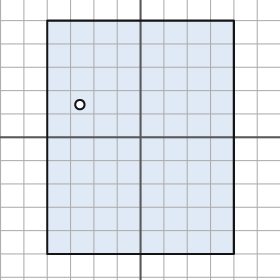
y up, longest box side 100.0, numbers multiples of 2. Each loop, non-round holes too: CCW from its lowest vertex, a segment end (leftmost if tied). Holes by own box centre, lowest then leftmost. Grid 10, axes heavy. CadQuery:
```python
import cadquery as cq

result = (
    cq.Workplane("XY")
    .moveTo(-40.0, -50.0)
    .lineTo(40.0, -50.0)
    .lineTo(40.0, 50.0)
    .lineTo(-40.0, 50.0)
    .close()
    .moveTo(-26.0, 14.0)
    .circle(2.0)
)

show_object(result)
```